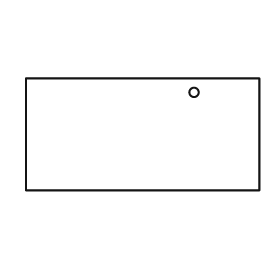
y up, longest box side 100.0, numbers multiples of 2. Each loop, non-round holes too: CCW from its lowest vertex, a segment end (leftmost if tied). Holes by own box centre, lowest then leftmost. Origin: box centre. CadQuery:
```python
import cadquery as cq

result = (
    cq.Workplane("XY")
    .moveTo(-50.0, -24.0)
    .lineTo(50.0, -24.0)
    .lineTo(50.0, 24.0)
    .lineTo(-50.0, 24.0)
    .close()
    .moveTo(22.0, 18.0)
    .circle(2.0)
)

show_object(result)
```